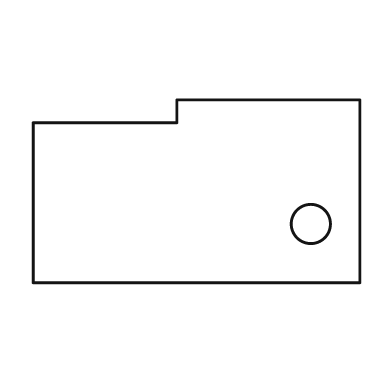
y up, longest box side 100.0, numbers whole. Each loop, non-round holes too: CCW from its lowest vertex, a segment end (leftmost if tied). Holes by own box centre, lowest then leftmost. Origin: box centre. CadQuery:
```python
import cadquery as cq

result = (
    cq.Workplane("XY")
    .moveTo(-50.0, -28.0)
    .lineTo(50.0, -28.0)
    .lineTo(50.0, 28.0)
    .lineTo(-6.0, 28.0)
    .lineTo(-6.0, 21.0)
    .lineTo(-50.0, 21.0)
    .close()
    .moveTo(35.0, -10.0)
    .circle(6.0)
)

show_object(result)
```